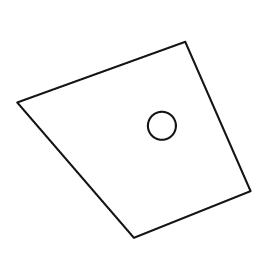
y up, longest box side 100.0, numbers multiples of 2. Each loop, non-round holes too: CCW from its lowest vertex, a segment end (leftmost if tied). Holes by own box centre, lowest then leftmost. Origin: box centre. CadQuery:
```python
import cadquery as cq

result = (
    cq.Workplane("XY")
    .moveTo(0.0, -42.0)
    .lineTo(50.0, -22.0)
    .lineTo(22.0, 42.0)
    .lineTo(-50.0, 16.0)
    .close()
    .moveTo(12.0, 6.0)
    .circle(6.0)
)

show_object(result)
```